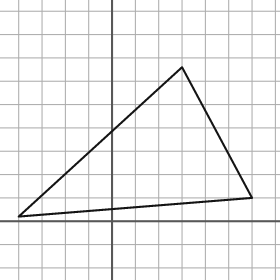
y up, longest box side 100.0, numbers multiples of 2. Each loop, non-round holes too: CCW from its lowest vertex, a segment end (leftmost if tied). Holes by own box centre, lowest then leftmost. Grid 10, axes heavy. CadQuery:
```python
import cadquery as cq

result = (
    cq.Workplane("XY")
    .moveTo(-40.0, 2.0)
    .lineTo(60.0, 10.0)
    .lineTo(30.0, 66.0)
    .close()
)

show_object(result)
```